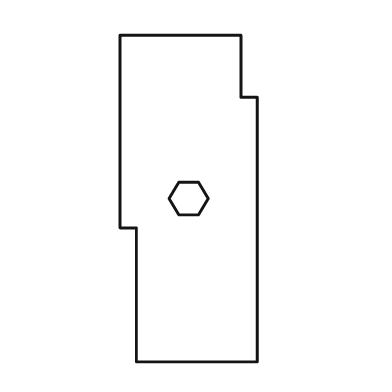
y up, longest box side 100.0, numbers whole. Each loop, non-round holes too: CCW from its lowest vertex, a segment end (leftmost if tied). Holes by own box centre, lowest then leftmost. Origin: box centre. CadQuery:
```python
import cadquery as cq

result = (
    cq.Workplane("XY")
    .moveTo(-16.0, -50.0)
    .lineTo(21.0, -50.0)
    .lineTo(21.0, 31.0)
    .lineTo(16.0, 31.0)
    .lineTo(16.0, 50.0)
    .lineTo(-21.0, 50.0)
    .lineTo(-21.0, -9.0)
    .lineTo(-16.0, -9.0)
    .close()
    .moveTo(-3.0, -5.0)
    .lineTo(3.0, -5.0)
    .lineTo(6.0, 0.0)
    .lineTo(3.0, 5.0)
    .lineTo(-3.0, 5.0)
    .lineTo(-6.0, 0.0)
    .close()
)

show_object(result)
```